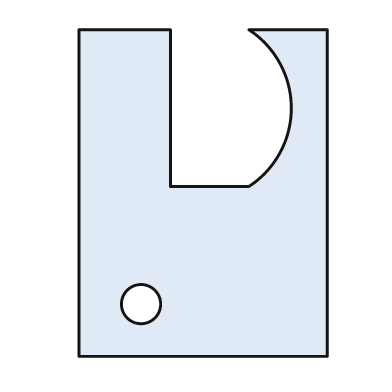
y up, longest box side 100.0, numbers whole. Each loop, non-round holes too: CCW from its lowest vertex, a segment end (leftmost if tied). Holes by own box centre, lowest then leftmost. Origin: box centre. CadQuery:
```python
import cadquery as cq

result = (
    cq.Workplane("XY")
    .moveTo(-38.0, -50.0)
    .lineTo(38.0, -50.0)
    .lineTo(38.0, 50.0)
    .lineTo(14.0, 50.0)
    .threePointArc((27.0, 26.0), (14.0, 2.0))
    .lineTo(-10.0, 2.0)
    .lineTo(-10.0, 50.0)
    .lineTo(-38.0, 50.0)
    .close()
    .moveTo(-19.0, -34.0)
    .circle(6.0)
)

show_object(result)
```